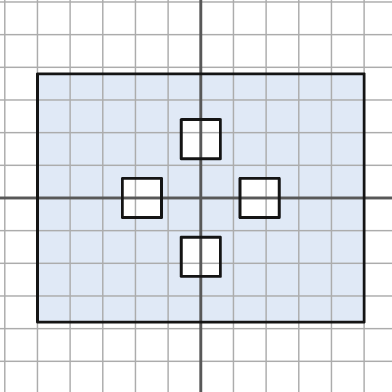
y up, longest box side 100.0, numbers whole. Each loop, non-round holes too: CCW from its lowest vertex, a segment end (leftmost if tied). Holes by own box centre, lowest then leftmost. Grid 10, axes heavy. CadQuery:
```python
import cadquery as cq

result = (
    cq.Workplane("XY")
    .moveTo(-50.0, -38.0)
    .lineTo(50.0, -38.0)
    .lineTo(50.0, 38.0)
    .lineTo(-50.0, 38.0)
    .close()
    .moveTo(-6.0, -24.0)
    .lineTo(6.0, -24.0)
    .lineTo(6.0, -12.0)
    .lineTo(-6.0, -12.0)
    .close()
    .moveTo(-24.0, -6.0)
    .lineTo(-12.0, -6.0)
    .lineTo(-12.0, 6.0)
    .lineTo(-24.0, 6.0)
    .close()
    .moveTo(12.0, -6.0)
    .lineTo(24.0, -6.0)
    .lineTo(24.0, 6.0)
    .lineTo(12.0, 6.0)
    .close()
    .moveTo(-6.0, 12.0)
    .lineTo(6.0, 12.0)
    .lineTo(6.0, 24.0)
    .lineTo(-6.0, 24.0)
    .close()
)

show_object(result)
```